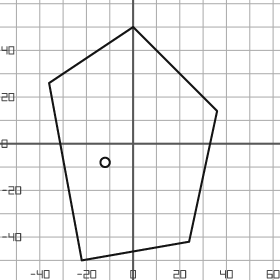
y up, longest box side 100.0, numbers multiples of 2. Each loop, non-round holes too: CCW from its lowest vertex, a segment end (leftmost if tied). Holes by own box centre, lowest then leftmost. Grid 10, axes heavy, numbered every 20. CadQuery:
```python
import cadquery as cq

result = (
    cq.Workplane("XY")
    .moveTo(-22.0, -50.0)
    .lineTo(24.0, -42.0)
    .lineTo(36.0, 14.0)
    .lineTo(0.0, 50.0)
    .lineTo(-36.0, 26.0)
    .close()
    .moveTo(-12.0, -8.0)
    .circle(2.0)
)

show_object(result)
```